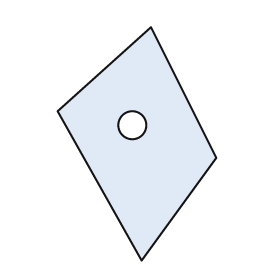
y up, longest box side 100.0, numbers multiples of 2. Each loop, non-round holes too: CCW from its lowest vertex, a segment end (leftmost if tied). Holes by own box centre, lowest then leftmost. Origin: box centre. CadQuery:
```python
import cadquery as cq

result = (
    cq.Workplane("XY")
    .moveTo(2.0, -50.0)
    .lineTo(34.0, -6.0)
    .lineTo(6.0, 50.0)
    .lineTo(-34.0, 14.0)
    .close()
    .moveTo(-2.0, 8.0)
    .circle(6.0)
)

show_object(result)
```